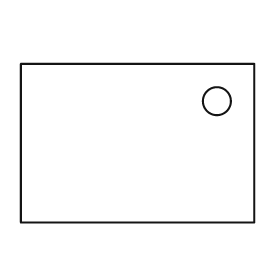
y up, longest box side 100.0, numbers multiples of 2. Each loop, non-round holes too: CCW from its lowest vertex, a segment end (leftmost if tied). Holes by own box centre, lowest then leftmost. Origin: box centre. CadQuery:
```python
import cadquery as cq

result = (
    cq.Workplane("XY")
    .moveTo(-50.0, -34.0)
    .lineTo(50.0, -34.0)
    .lineTo(50.0, 34.0)
    .lineTo(-50.0, 34.0)
    .close()
    .moveTo(34.0, 18.0)
    .circle(6.0)
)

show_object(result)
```